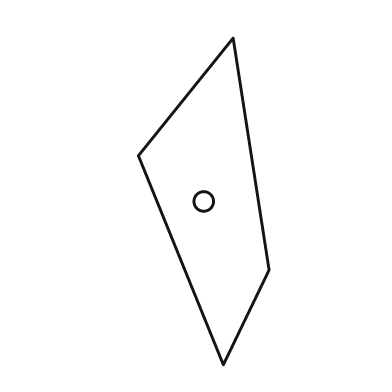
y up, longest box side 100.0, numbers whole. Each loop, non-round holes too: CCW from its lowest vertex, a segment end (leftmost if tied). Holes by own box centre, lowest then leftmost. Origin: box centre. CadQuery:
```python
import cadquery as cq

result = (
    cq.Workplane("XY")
    .moveTo(6.0, -50.0)
    .lineTo(20.0, -21.0)
    .lineTo(9.0, 50.0)
    .lineTo(-20.0, 14.0)
    .close()
    .moveTo(0.0, 0.0)
    .circle(3.0)
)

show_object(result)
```